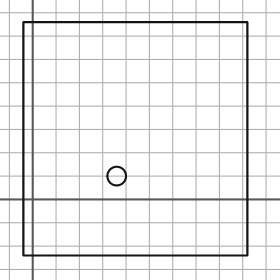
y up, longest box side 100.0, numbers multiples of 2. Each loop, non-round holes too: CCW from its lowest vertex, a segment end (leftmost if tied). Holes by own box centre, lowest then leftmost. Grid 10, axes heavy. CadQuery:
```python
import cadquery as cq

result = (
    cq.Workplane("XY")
    .moveTo(-4.0, -24.0)
    .lineTo(92.0, -24.0)
    .lineTo(92.0, 76.0)
    .lineTo(-4.0, 76.0)
    .close()
    .moveTo(36.0, 10.0)
    .circle(4.0)
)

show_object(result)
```